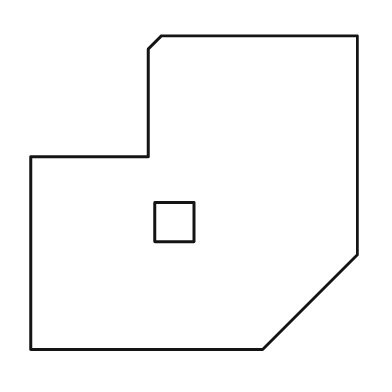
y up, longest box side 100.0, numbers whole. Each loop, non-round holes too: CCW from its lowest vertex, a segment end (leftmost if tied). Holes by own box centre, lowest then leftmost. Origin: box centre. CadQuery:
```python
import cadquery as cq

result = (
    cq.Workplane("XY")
    .moveTo(-50.0, -48.0)
    .lineTo(21.0, -48.0)
    .lineTo(50.0, -19.0)
    .lineTo(50.0, 48.0)
    .lineTo(-10.0, 48.0)
    .lineTo(-14.0, 44.0)
    .lineTo(-14.0, 11.0)
    .lineTo(-50.0, 11.0)
    .close()
    .moveTo(-12.0, -15.0)
    .lineTo(0.0, -15.0)
    .lineTo(0.0, -3.0)
    .lineTo(-12.0, -3.0)
    .close()
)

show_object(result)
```